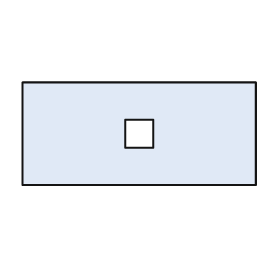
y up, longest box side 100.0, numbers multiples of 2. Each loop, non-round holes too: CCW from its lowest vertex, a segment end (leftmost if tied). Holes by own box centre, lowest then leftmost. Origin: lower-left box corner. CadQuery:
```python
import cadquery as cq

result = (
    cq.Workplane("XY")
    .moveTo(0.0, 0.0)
    .lineTo(100.0, 0.0)
    .lineTo(100.0, 44.0)
    .lineTo(0.0, 44.0)
    .close()
    .moveTo(44.0, 16.0)
    .lineTo(56.0, 16.0)
    .lineTo(56.0, 28.0)
    .lineTo(44.0, 28.0)
    .close()
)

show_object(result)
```